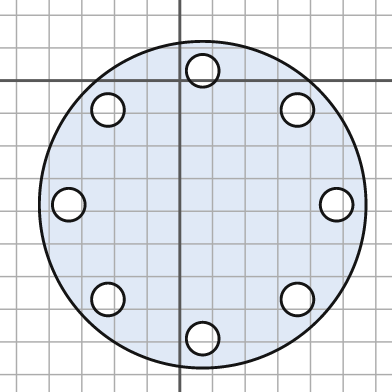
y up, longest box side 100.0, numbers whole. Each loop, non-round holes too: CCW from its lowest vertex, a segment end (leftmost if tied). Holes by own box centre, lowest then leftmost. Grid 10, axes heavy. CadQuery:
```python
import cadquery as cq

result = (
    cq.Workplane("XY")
    .moveTo(7.0, -38.0)
    .circle(50.0)
    .moveTo(7.0, -79.0)
    .circle(5.0)
    .moveTo(-22.0, -67.0)
    .circle(5.0)
    .moveTo(36.0, -67.0)
    .circle(5.0)
    .moveTo(-34.0, -38.0)
    .circle(5.0)
    .moveTo(48.0, -38.0)
    .circle(5.0)
    .moveTo(-22.0, -9.0)
    .circle(5.0)
    .moveTo(36.0, -9.0)
    .circle(5.0)
    .moveTo(7.0, 3.0)
    .circle(5.0)
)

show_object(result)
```